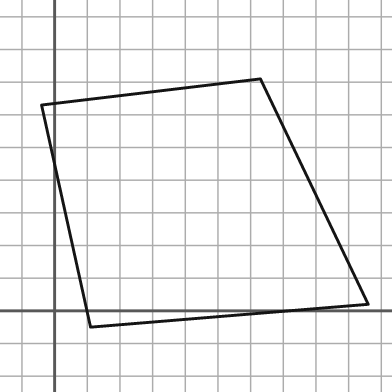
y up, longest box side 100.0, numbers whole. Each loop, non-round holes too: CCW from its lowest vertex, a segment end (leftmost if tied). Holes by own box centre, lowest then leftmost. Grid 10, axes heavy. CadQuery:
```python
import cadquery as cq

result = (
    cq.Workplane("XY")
    .moveTo(11.0, -5.0)
    .lineTo(96.0, 2.0)
    .lineTo(63.0, 71.0)
    .lineTo(-4.0, 63.0)
    .close()
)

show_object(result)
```